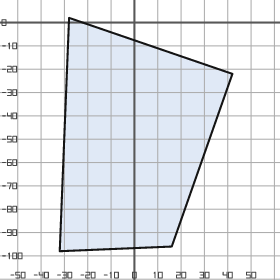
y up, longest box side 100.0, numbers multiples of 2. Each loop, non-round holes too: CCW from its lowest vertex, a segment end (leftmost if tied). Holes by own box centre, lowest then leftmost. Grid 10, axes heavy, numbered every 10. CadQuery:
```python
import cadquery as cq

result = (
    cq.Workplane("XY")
    .moveTo(-32.0, -98.0)
    .lineTo(16.0, -96.0)
    .lineTo(42.0, -22.0)
    .lineTo(-28.0, 2.0)
    .close()
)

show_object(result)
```